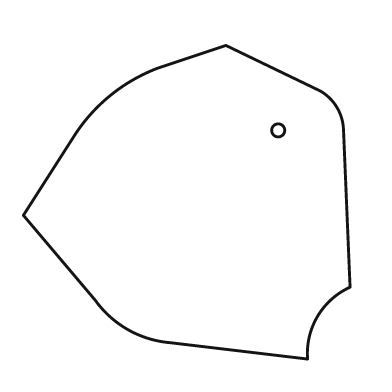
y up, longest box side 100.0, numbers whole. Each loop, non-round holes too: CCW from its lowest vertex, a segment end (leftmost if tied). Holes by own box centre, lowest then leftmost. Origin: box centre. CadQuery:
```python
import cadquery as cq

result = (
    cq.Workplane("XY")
    .moveTo(37.0, -48.0)
    .threePointArc((40.0, -35.0), (50.0, -26.0))
    .lineTo(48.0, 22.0)
    .threePointArc((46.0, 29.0), (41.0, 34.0))
    .lineTo(12.0, 48.0)
    .lineTo(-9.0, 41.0)
    .threePointArc((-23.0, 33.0), (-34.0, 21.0))
    .lineTo(-50.0, -4.0)
    .lineTo(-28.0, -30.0)
    .threePointArc((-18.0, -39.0), (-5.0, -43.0))
    .close()
    .moveTo(28.0, 22.0)
    .circle(2.0)
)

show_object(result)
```